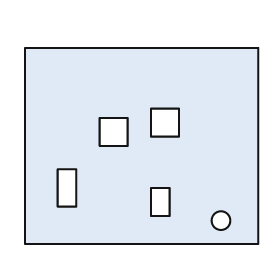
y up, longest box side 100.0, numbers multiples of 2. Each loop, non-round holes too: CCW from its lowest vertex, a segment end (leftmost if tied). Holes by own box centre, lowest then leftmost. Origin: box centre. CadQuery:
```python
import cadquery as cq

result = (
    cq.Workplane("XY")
    .moveTo(-50.0, -42.0)
    .lineTo(50.0, -42.0)
    .lineTo(50.0, 42.0)
    .lineTo(-50.0, 42.0)
    .close()
    .moveTo(34.0, -32.0)
    .circle(4.0)
    .moveTo(4.0, -30.0)
    .lineTo(12.0, -30.0)
    .lineTo(12.0, -18.0)
    .lineTo(4.0, -18.0)
    .close()
    .moveTo(-36.0, -26.0)
    .lineTo(-28.0, -26.0)
    .lineTo(-28.0, -10.0)
    .lineTo(-36.0, -10.0)
    .close()
    .moveTo(-18.0, 0.0)
    .lineTo(-6.0, 0.0)
    .lineTo(-6.0, 12.0)
    .lineTo(-18.0, 12.0)
    .close()
    .moveTo(4.0, 4.0)
    .lineTo(16.0, 4.0)
    .lineTo(16.0, 16.0)
    .lineTo(4.0, 16.0)
    .close()
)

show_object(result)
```